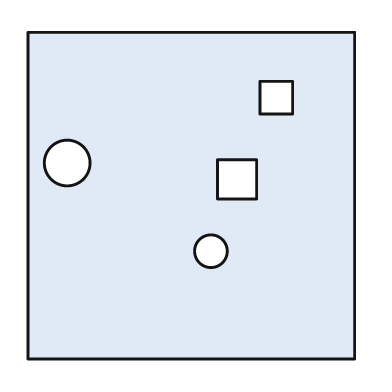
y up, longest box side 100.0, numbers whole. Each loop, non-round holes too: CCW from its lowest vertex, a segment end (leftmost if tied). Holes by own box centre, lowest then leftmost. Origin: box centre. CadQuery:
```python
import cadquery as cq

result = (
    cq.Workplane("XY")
    .moveTo(-50.0, -50.0)
    .lineTo(50.0, -50.0)
    .lineTo(50.0, 50.0)
    .lineTo(-50.0, 50.0)
    .close()
    .moveTo(6.0, -17.0)
    .circle(5.0)
    .moveTo(8.0, -1.0)
    .lineTo(20.0, -1.0)
    .lineTo(20.0, 11.0)
    .lineTo(8.0, 11.0)
    .close()
    .moveTo(-38.0, 10.0)
    .circle(7.0)
    .moveTo(21.0, 25.0)
    .lineTo(31.0, 25.0)
    .lineTo(31.0, 35.0)
    .lineTo(21.0, 35.0)
    .close()
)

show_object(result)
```